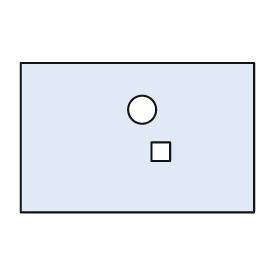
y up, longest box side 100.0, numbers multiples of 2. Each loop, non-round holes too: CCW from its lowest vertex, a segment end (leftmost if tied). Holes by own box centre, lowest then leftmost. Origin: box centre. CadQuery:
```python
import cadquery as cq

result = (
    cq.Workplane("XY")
    .moveTo(-50.0, -32.0)
    .lineTo(50.0, -32.0)
    .lineTo(50.0, 32.0)
    .lineTo(-50.0, 32.0)
    .close()
    .moveTo(6.0, -10.0)
    .lineTo(14.0, -10.0)
    .lineTo(14.0, -2.0)
    .lineTo(6.0, -2.0)
    .close()
    .moveTo(2.0, 12.0)
    .circle(6.0)
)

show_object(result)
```